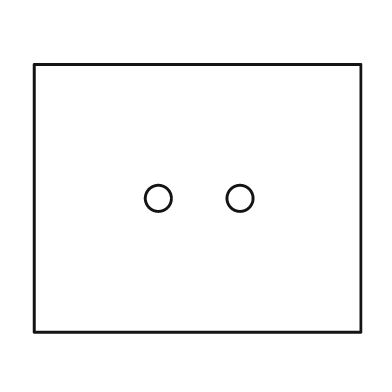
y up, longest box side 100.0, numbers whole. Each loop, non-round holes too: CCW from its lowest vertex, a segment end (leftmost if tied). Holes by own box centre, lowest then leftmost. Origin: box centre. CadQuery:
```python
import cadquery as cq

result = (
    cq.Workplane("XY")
    .moveTo(-50.0, -41.0)
    .lineTo(50.0, -41.0)
    .lineTo(50.0, 41.0)
    .lineTo(-50.0, 41.0)
    .close()
    .moveTo(-12.0, 0.0)
    .circle(4.0)
    .moveTo(13.0, 0.0)
    .circle(4.0)
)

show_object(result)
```